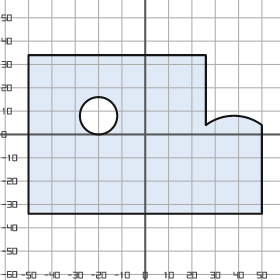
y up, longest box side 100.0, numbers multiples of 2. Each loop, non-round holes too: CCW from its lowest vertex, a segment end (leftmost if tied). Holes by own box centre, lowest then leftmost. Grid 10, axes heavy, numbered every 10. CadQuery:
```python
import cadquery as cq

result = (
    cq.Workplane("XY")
    .moveTo(-50.0, -34.0)
    .lineTo(50.0, -34.0)
    .lineTo(50.0, 4.0)
    .threePointArc((38.0, 8.0), (26.0, 4.0))
    .lineTo(26.0, 34.0)
    .lineTo(-50.0, 34.0)
    .close()
    .moveTo(-20.0, 8.0)
    .circle(8.0)
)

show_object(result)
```